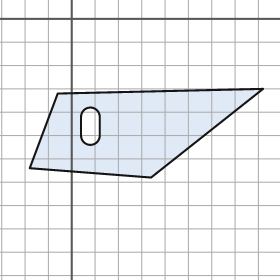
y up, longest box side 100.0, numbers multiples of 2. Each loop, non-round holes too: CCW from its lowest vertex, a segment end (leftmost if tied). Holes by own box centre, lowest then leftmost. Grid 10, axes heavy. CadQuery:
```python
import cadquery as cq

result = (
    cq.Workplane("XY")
    .moveTo(34.0, -68.0)
    .lineTo(82.0, -30.0)
    .lineTo(-6.0, -32.0)
    .lineTo(-18.0, -64.0)
    .close()
    .moveTo(4.0, -50.0)
    .threePointArc((8.0, -54.0), (12.0, -50.0))
    .lineTo(12.0, -42.0)
    .threePointArc((8.0, -38.0), (4.0, -42.0))
    .close()
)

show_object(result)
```